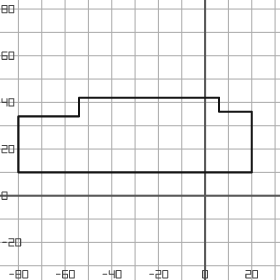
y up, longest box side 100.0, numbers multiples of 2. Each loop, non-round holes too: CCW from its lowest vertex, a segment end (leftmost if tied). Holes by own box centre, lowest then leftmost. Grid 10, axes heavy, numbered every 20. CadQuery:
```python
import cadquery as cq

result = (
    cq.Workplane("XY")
    .moveTo(-80.0, 10.0)
    .lineTo(20.0, 10.0)
    .lineTo(20.0, 36.0)
    .lineTo(6.0, 36.0)
    .lineTo(6.0, 42.0)
    .lineTo(-54.0, 42.0)
    .lineTo(-54.0, 34.0)
    .lineTo(-80.0, 34.0)
    .close()
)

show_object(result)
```